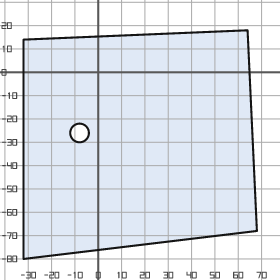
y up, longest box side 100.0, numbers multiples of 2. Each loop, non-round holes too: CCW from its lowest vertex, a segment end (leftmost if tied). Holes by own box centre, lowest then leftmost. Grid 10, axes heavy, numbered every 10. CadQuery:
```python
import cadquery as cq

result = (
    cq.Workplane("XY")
    .moveTo(-32.0, -80.0)
    .lineTo(68.0, -68.0)
    .lineTo(64.0, 18.0)
    .lineTo(-32.0, 14.0)
    .close()
    .moveTo(-8.0, -26.0)
    .circle(4.0)
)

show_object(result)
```